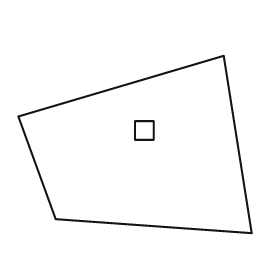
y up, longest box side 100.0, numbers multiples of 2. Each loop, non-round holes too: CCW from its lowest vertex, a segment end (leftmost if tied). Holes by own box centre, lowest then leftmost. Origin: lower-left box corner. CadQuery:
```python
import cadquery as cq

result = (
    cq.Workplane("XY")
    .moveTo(100.0, 0.0)
    .lineTo(88.0, 76.0)
    .lineTo(0.0, 50.0)
    .lineTo(16.0, 6.0)
    .close()
    .moveTo(50.0, 40.0)
    .lineTo(58.0, 40.0)
    .lineTo(58.0, 48.0)
    .lineTo(50.0, 48.0)
    .close()
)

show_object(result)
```